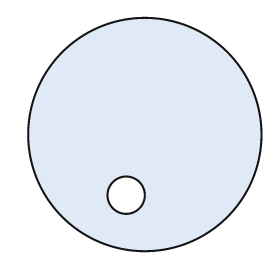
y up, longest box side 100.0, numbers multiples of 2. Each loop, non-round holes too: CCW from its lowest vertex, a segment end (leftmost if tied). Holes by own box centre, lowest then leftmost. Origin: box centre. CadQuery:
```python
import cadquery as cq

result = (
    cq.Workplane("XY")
    .moveTo(0.0, 0.0)
    .circle(50.0)
    .moveTo(-8.0, -26.0)
    .circle(8.0)
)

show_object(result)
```